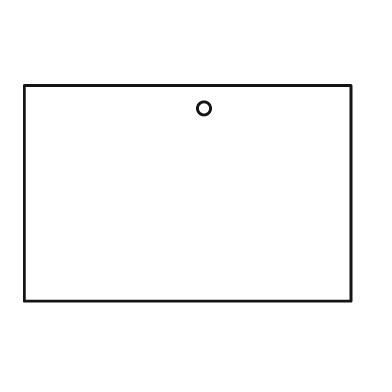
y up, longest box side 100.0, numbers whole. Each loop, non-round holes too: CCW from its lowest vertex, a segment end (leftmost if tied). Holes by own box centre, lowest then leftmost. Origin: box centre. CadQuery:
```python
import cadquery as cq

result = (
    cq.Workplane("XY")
    .moveTo(-50.0, -33.0)
    .lineTo(50.0, -33.0)
    .lineTo(50.0, 33.0)
    .lineTo(-50.0, 33.0)
    .close()
    .moveTo(5.0, 26.0)
    .circle(2.0)
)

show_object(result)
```